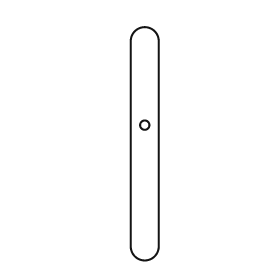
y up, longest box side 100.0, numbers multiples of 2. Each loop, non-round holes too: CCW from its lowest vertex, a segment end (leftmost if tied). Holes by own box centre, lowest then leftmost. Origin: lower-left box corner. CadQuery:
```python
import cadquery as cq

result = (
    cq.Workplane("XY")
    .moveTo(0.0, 6.0)
    .threePointArc((6.0, 0.0), (12.0, 6.0))
    .lineTo(12.0, 94.0)
    .threePointArc((6.0, 100.0), (0.0, 94.0))
    .close()
    .moveTo(6.0, 58.0)
    .circle(2.0)
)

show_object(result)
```